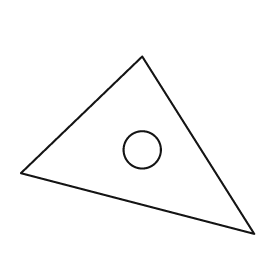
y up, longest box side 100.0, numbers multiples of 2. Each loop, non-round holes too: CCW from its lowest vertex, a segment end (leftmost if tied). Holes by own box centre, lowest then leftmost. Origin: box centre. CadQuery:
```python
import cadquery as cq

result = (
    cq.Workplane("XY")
    .moveTo(50.0, -38.0)
    .lineTo(2.0, 38.0)
    .lineTo(-50.0, -12.0)
    .close()
    .moveTo(2.0, -2.0)
    .circle(8.0)
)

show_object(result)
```